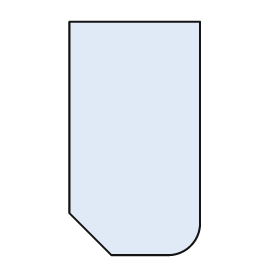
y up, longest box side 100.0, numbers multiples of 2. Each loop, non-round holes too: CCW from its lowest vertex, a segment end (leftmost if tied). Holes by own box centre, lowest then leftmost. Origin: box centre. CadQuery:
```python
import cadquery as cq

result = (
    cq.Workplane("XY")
    .moveTo(-10.0, -50.0)
    .lineTo(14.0, -50.0)
    .threePointArc((24.0, -46.0), (28.0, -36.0))
    .lineTo(28.0, 50.0)
    .lineTo(-28.0, 50.0)
    .lineTo(-28.0, -32.0)
    .close()
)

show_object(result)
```